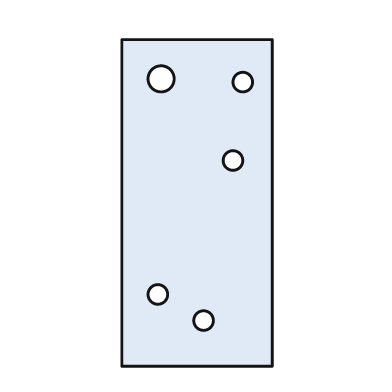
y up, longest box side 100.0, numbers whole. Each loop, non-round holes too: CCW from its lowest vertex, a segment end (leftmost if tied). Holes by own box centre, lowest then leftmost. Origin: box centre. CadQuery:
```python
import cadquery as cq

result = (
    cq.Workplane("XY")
    .moveTo(-23.0, -50.0)
    .lineTo(23.0, -50.0)
    .lineTo(23.0, 50.0)
    .lineTo(-23.0, 50.0)
    .close()
    .moveTo(2.0, -36.0)
    .circle(3.0)
    .moveTo(-12.0, -28.0)
    .circle(3.0)
    .moveTo(11.0, 13.0)
    .circle(3.0)
    .moveTo(14.0, 37.0)
    .circle(3.0)
    .moveTo(-11.0, 38.0)
    .circle(4.0)
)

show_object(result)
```